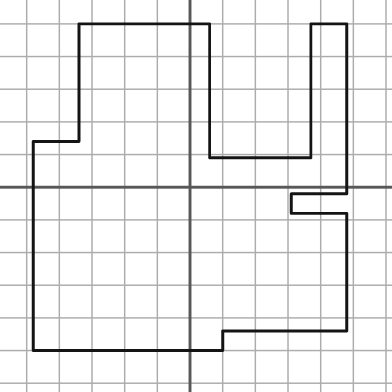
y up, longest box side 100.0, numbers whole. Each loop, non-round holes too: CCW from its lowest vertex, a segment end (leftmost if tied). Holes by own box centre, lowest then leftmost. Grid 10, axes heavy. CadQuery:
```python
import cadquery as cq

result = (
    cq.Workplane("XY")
    .moveTo(-48.0, -50.0)
    .lineTo(10.0, -50.0)
    .lineTo(10.0, -44.0)
    .lineTo(48.0, -44.0)
    .lineTo(48.0, -8.0)
    .lineTo(31.0, -8.0)
    .lineTo(31.0, -2.0)
    .lineTo(48.0, -2.0)
    .lineTo(48.0, 50.0)
    .lineTo(37.0, 50.0)
    .lineTo(37.0, 9.0)
    .lineTo(6.0, 9.0)
    .lineTo(6.0, 50.0)
    .lineTo(-34.0, 50.0)
    .lineTo(-34.0, 14.0)
    .lineTo(-48.0, 14.0)
    .close()
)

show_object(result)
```